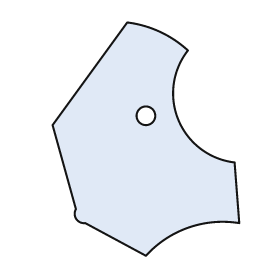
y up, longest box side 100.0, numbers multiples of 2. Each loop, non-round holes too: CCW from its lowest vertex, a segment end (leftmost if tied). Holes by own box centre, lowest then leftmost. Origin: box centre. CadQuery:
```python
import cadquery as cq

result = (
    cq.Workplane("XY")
    .moveTo(0.0, -50.0)
    .threePointArc((18.0, -38.0), (40.0, -36.0))
    .lineTo(38.0, -10.0)
    .threePointArc((14.0, 8.0), (18.0, 38.0))
    .threePointArc((6.0, 46.0), (-8.0, 50.0))
    .lineTo(-40.0, 6.0)
    .lineTo(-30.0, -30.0)
    .threePointArc((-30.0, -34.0), (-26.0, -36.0))
    .close()
    .moveTo(0.0, 10.0)
    .circle(4.0)
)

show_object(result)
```